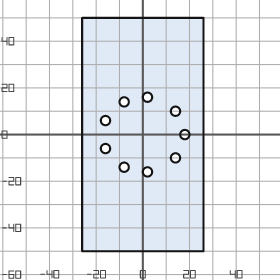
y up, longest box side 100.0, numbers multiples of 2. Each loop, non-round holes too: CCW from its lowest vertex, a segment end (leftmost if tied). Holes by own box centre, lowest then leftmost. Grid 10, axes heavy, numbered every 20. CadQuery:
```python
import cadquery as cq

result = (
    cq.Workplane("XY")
    .moveTo(-26.0, -50.0)
    .lineTo(26.0, -50.0)
    .lineTo(26.0, 50.0)
    .lineTo(-26.0, 50.0)
    .close()
    .moveTo(2.0, -16.0)
    .circle(2.0)
    .moveTo(-8.0, -14.0)
    .circle(2.0)
    .moveTo(14.0, -10.0)
    .circle(2.0)
    .moveTo(-16.0, -6.0)
    .circle(2.0)
    .moveTo(18.0, 0.0)
    .circle(2.0)
    .moveTo(-16.0, 6.0)
    .circle(2.0)
    .moveTo(14.0, 10.0)
    .circle(2.0)
    .moveTo(-8.0, 14.0)
    .circle(2.0)
    .moveTo(2.0, 16.0)
    .circle(2.0)
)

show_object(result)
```